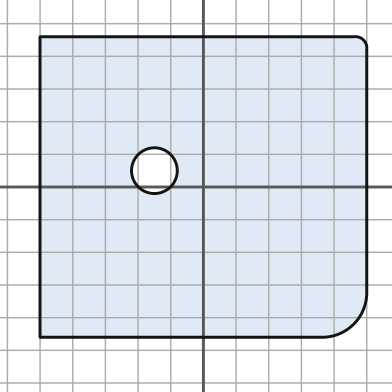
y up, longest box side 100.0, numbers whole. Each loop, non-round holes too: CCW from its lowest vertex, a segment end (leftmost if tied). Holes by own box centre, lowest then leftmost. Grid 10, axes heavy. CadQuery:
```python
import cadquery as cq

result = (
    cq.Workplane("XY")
    .moveTo(-50.0, -46.0)
    .lineTo(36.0, -46.0)
    .threePointArc((46.0, -42.0), (50.0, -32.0))
    .lineTo(50.0, 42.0)
    .threePointArc((49.0, 45.0), (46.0, 46.0))
    .lineTo(-50.0, 46.0)
    .close()
    .moveTo(-15.0, 5.0)
    .circle(7.0)
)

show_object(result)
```